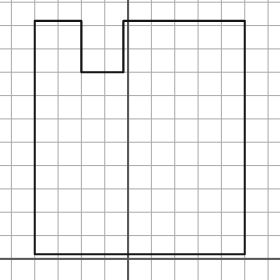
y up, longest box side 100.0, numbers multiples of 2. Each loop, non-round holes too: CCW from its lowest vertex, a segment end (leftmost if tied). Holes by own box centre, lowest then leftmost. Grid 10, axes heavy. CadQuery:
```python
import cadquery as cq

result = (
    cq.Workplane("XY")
    .moveTo(-40.0, 2.0)
    .lineTo(50.0, 2.0)
    .lineTo(50.0, 102.0)
    .lineTo(-2.0, 102.0)
    .lineTo(-2.0, 80.0)
    .lineTo(-20.0, 80.0)
    .lineTo(-20.0, 102.0)
    .lineTo(-40.0, 102.0)
    .close()
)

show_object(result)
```